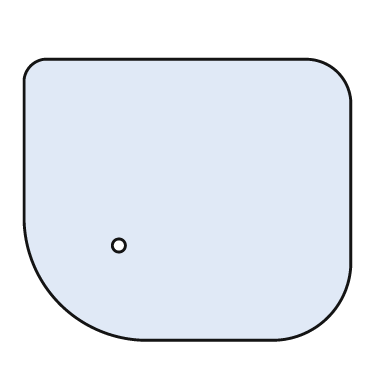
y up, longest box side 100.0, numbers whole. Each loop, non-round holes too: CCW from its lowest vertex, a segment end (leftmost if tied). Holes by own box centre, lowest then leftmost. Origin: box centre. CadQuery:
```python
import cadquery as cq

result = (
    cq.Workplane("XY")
    .moveTo(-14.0, -43.0)
    .lineTo(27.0, -43.0)
    .threePointArc((43.0, -36.0), (50.0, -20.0))
    .lineTo(50.0, 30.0)
    .threePointArc((46.0, 39.0), (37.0, 43.0))
    .lineTo(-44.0, 43.0)
    .threePointArc((-48.0, 41.0), (-50.0, 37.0))
    .lineTo(-50.0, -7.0)
    .threePointArc((-39.0, -32.0), (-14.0, -43.0))
    .close()
    .moveTo(-21.0, -14.0)
    .circle(2.0)
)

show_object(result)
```